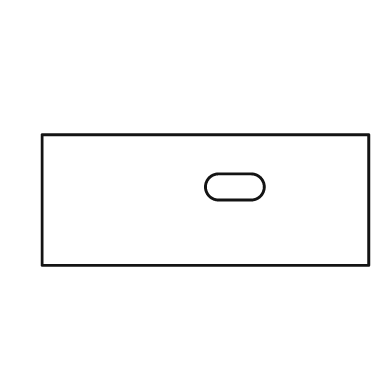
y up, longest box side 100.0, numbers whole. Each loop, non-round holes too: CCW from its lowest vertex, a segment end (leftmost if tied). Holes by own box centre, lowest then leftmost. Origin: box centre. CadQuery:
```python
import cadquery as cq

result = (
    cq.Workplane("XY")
    .moveTo(-50.0, -20.0)
    .lineTo(50.0, -20.0)
    .lineTo(50.0, 20.0)
    .lineTo(-50.0, 20.0)
    .close()
    .moveTo(4.0, 0.0)
    .lineTo(14.0, 0.0)
    .threePointArc((18.0, 4.0), (14.0, 8.0))
    .lineTo(4.0, 8.0)
    .threePointArc((0.0, 4.0), (4.0, 0.0))
    .close()
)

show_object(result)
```